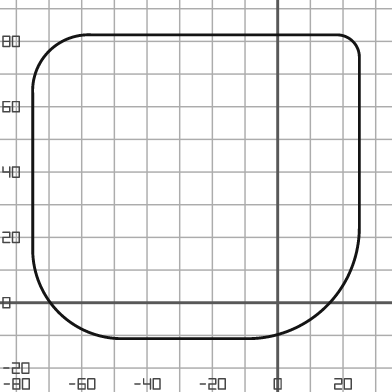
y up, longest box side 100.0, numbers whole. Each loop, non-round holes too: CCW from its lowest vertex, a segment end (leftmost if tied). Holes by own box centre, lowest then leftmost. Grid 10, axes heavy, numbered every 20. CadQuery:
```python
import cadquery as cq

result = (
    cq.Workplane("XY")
    .moveTo(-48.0, -11.0)
    .lineTo(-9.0, -11.0)
    .threePointArc((15.0, -1.0), (25.0, 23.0))
    .lineTo(25.0, 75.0)
    .threePointArc((23.0, 80.0), (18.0, 82.0))
    .lineTo(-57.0, 82.0)
    .threePointArc((-70.0, 77.0), (-75.0, 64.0))
    .lineTo(-75.0, 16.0)
    .threePointArc((-67.0, -3.0), (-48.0, -11.0))
    .close()
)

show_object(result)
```